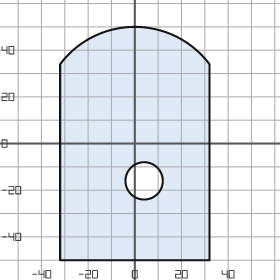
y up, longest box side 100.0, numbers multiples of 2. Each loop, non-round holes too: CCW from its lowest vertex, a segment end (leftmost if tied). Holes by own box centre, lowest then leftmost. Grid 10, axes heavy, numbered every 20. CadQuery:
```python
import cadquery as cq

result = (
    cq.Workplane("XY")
    .moveTo(-32.0, -50.0)
    .lineTo(32.0, -50.0)
    .lineTo(32.0, 34.0)
    .threePointArc((0.0, 50.0), (-32.0, 34.0))
    .close()
    .moveTo(4.0, -16.0)
    .circle(8.0)
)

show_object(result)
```